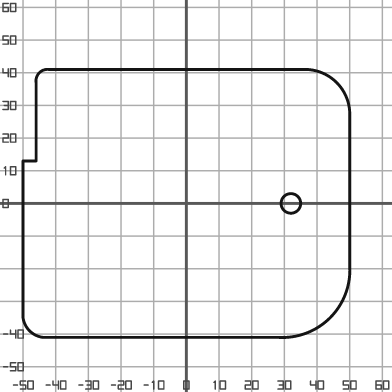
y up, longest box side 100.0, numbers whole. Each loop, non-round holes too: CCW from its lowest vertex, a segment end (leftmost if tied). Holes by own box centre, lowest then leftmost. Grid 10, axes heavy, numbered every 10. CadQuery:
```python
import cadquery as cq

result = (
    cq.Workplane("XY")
    .moveTo(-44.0, -41.0)
    .lineTo(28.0, -41.0)
    .threePointArc((44.0, -35.0), (50.0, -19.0))
    .lineTo(50.0, 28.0)
    .threePointArc((46.0, 37.0), (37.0, 41.0))
    .lineTo(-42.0, 41.0)
    .threePointArc((-45.0, 40.0), (-46.0, 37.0))
    .lineTo(-46.0, 13.0)
    .lineTo(-50.0, 13.0)
    .lineTo(-50.0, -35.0)
    .threePointArc((-48.0, -39.0), (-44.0, -41.0))
    .close()
    .moveTo(32.0, 0.0)
    .circle(3.0)
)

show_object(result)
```